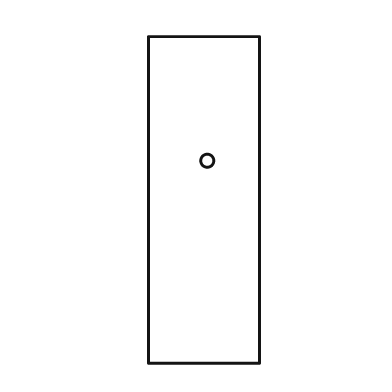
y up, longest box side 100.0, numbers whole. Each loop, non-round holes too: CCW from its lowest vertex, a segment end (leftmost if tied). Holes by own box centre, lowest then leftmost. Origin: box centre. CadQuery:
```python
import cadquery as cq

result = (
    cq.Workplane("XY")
    .moveTo(-17.0, -50.0)
    .lineTo(17.0, -50.0)
    .lineTo(17.0, 50.0)
    .lineTo(-17.0, 50.0)
    .close()
    .moveTo(1.0, 12.0)
    .circle(2.0)
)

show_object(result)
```